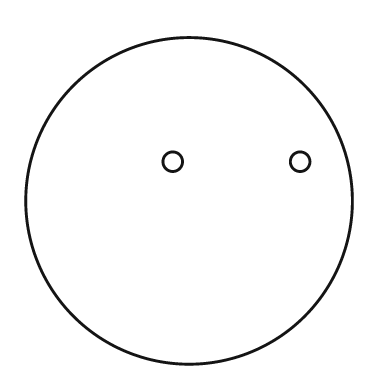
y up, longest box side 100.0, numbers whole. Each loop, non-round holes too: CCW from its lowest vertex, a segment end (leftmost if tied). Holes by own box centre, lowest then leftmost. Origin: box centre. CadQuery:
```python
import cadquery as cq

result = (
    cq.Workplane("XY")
    .moveTo(0.0, 0.0)
    .circle(50.0)
    .moveTo(-5.0, 12.0)
    .circle(3.0)
    .moveTo(34.0, 12.0)
    .circle(3.0)
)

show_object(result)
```